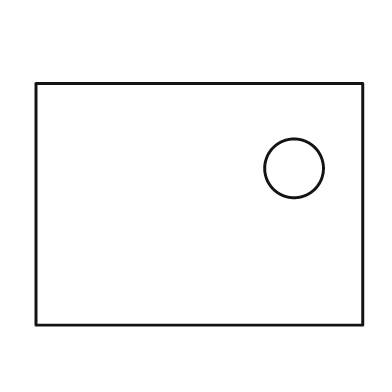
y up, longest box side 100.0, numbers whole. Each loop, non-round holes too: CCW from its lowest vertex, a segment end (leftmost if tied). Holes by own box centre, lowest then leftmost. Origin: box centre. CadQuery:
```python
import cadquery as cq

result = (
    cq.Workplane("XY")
    .moveTo(-50.0, -37.0)
    .lineTo(50.0, -37.0)
    .lineTo(50.0, 37.0)
    .lineTo(-50.0, 37.0)
    .close()
    .moveTo(29.0, 11.0)
    .circle(9.0)
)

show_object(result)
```